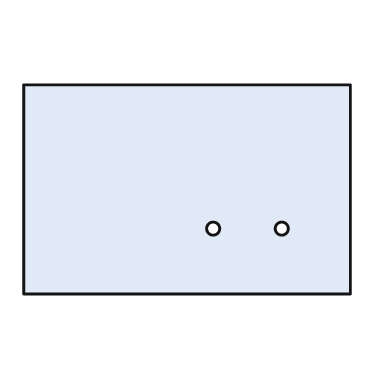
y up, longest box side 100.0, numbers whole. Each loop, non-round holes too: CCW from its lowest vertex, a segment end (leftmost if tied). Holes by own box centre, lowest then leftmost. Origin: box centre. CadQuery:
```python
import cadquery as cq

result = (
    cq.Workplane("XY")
    .moveTo(-50.0, -32.0)
    .lineTo(50.0, -32.0)
    .lineTo(50.0, 32.0)
    .lineTo(-50.0, 32.0)
    .close()
    .moveTo(8.0, -12.0)
    .circle(2.0)
    .moveTo(29.0, -12.0)
    .circle(2.0)
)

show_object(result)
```